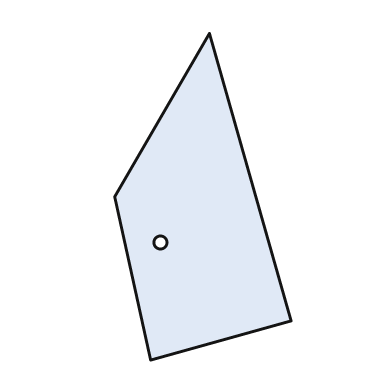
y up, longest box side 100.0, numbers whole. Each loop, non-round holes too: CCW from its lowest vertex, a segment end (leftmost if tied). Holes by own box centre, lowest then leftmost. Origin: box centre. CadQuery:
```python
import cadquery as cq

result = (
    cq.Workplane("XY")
    .moveTo(-16.0, -50.0)
    .lineTo(27.0, -38.0)
    .lineTo(2.0, 50.0)
    .lineTo(-27.0, 0.0)
    .close()
    .moveTo(-13.0, -14.0)
    .circle(2.0)
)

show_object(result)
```